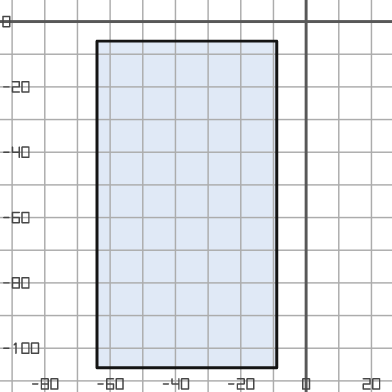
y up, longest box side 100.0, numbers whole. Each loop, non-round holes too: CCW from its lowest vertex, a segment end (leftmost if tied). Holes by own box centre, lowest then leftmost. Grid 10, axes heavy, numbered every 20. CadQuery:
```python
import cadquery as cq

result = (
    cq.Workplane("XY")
    .moveTo(-64.0, -106.0)
    .lineTo(-9.0, -106.0)
    .lineTo(-9.0, -6.0)
    .lineTo(-64.0, -6.0)
    .close()
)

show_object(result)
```